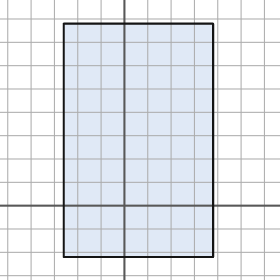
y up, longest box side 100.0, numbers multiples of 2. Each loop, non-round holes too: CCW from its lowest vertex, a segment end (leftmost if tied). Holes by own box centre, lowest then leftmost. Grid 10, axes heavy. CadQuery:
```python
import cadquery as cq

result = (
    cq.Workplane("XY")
    .moveTo(-26.0, -22.0)
    .lineTo(38.0, -22.0)
    .lineTo(38.0, 78.0)
    .lineTo(-26.0, 78.0)
    .close()
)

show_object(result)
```